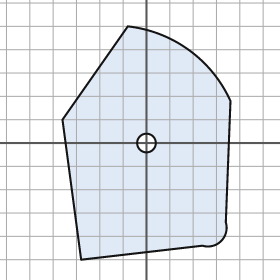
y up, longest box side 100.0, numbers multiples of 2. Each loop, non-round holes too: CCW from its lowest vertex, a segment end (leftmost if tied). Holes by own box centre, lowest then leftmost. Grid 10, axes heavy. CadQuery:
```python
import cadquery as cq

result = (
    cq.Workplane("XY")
    .moveTo(-28.0, -50.0)
    .lineTo(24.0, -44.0)
    .threePointArc((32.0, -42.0), (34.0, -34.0))
    .lineTo(36.0, 18.0)
    .threePointArc((18.0, 40.0), (-8.0, 50.0))
    .lineTo(-36.0, 10.0)
    .close()
    .moveTo(0.0, 0.0)
    .circle(4.0)
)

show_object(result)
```